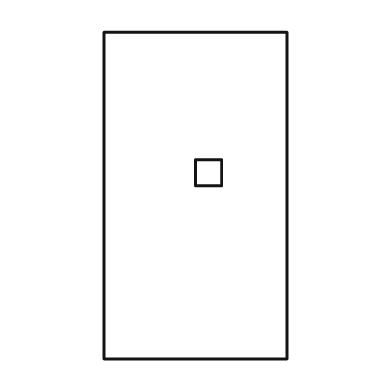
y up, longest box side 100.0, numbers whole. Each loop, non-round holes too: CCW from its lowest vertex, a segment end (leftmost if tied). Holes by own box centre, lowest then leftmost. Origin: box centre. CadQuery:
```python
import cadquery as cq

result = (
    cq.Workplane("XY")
    .moveTo(-28.0, -50.0)
    .lineTo(28.0, -50.0)
    .lineTo(28.0, 50.0)
    .lineTo(-28.0, 50.0)
    .close()
    .moveTo(0.0, 3.0)
    .lineTo(8.0, 3.0)
    .lineTo(8.0, 11.0)
    .lineTo(0.0, 11.0)
    .close()
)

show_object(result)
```